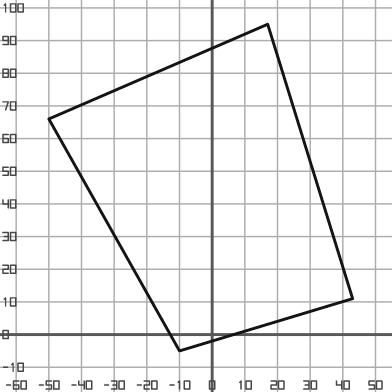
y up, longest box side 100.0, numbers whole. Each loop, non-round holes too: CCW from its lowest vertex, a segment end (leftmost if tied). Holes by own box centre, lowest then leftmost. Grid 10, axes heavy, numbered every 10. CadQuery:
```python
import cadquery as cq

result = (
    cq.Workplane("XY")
    .moveTo(-10.0, -5.0)
    .lineTo(43.0, 11.0)
    .lineTo(17.0, 95.0)
    .lineTo(-50.0, 66.0)
    .close()
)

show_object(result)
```